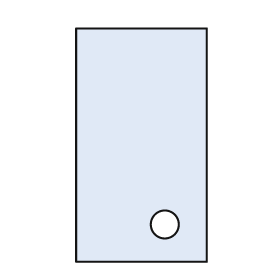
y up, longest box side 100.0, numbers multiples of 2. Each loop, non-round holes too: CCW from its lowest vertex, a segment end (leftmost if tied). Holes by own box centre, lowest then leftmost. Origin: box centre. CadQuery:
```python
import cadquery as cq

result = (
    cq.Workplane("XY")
    .moveTo(-28.0, -50.0)
    .lineTo(28.0, -50.0)
    .lineTo(28.0, 50.0)
    .lineTo(-28.0, 50.0)
    .close()
    .moveTo(10.0, -34.0)
    .circle(6.0)
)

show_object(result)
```